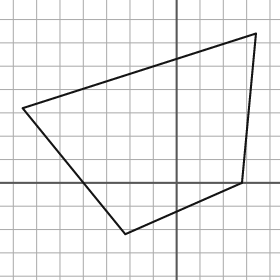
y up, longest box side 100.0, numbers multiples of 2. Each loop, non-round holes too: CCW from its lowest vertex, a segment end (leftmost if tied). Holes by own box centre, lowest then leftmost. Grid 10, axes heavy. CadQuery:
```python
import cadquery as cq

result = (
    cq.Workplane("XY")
    .moveTo(-22.0, -22.0)
    .lineTo(28.0, 0.0)
    .lineTo(34.0, 64.0)
    .lineTo(-66.0, 32.0)
    .close()
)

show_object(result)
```